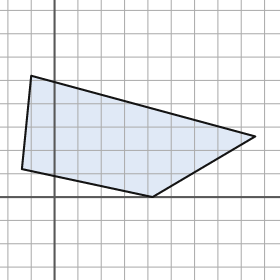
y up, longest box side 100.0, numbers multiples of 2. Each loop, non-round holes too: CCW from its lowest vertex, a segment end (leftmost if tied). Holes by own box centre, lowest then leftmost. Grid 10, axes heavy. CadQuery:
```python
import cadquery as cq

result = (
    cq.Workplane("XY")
    .moveTo(42.0, 0.0)
    .lineTo(86.0, 26.0)
    .lineTo(-10.0, 52.0)
    .lineTo(-14.0, 12.0)
    .close()
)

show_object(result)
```